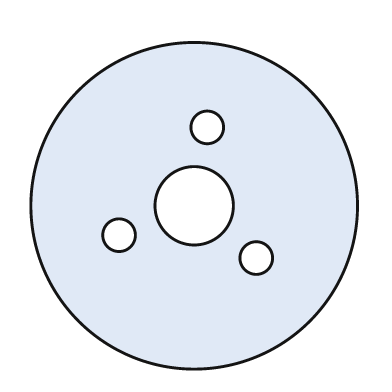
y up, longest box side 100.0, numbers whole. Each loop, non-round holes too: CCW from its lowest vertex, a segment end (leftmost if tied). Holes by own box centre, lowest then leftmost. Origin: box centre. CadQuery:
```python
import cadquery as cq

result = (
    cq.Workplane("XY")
    .moveTo(0.0, 0.0)
    .circle(50.0)
    .moveTo(19.0, -16.0)
    .circle(5.0)
    .moveTo(-23.0, -9.0)
    .circle(5.0)
    .moveTo(0.0, 0.0)
    .circle(12.0)
    .moveTo(4.0, 24.0)
    .circle(5.0)
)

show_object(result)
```